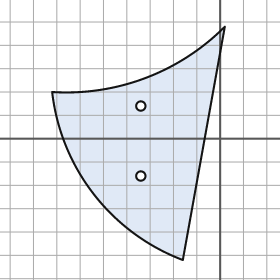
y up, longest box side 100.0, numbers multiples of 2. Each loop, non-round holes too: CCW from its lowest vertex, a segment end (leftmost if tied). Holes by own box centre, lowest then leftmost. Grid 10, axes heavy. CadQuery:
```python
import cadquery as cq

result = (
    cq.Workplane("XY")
    .moveTo(-16.0, -52.0)
    .lineTo(2.0, 48.0)
    .threePointArc((-32.0, 26.0), (-72.0, 20.0))
    .threePointArc((-54.0, -24.0), (-16.0, -52.0))
    .close()
    .moveTo(-34.0, -16.0)
    .circle(2.0)
    .moveTo(-34.0, 14.0)
    .circle(2.0)
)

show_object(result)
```